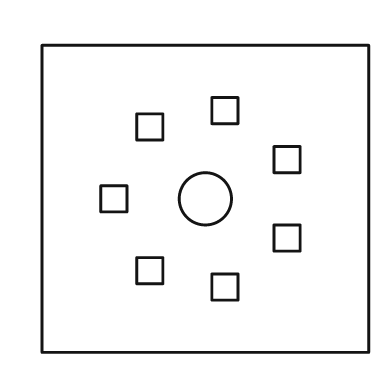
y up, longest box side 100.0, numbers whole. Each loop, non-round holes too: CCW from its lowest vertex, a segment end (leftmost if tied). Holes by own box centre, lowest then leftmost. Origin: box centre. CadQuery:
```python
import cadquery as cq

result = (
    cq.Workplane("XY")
    .moveTo(-50.0, -47.0)
    .lineTo(50.0, -47.0)
    .lineTo(50.0, 47.0)
    .lineTo(-50.0, 47.0)
    .close()
    .moveTo(2.0, -31.0)
    .lineTo(10.0, -31.0)
    .lineTo(10.0, -23.0)
    .lineTo(2.0, -23.0)
    .close()
    .moveTo(-21.0, -26.0)
    .lineTo(-13.0, -26.0)
    .lineTo(-13.0, -18.0)
    .lineTo(-21.0, -18.0)
    .close()
    .moveTo(21.0, -16.0)
    .lineTo(29.0, -16.0)
    .lineTo(29.0, -8.0)
    .lineTo(21.0, -8.0)
    .close()
    .moveTo(-32.0, -4.0)
    .lineTo(-24.0, -4.0)
    .lineTo(-24.0, 4.0)
    .lineTo(-32.0, 4.0)
    .close()
    .moveTo(0.0, 0.0)
    .circle(8.0)
    .moveTo(21.0, 8.0)
    .lineTo(29.0, 8.0)
    .lineTo(29.0, 16.0)
    .lineTo(21.0, 16.0)
    .close()
    .moveTo(-21.0, 18.0)
    .lineTo(-13.0, 18.0)
    .lineTo(-13.0, 26.0)
    .lineTo(-21.0, 26.0)
    .close()
    .moveTo(2.0, 23.0)
    .lineTo(10.0, 23.0)
    .lineTo(10.0, 31.0)
    .lineTo(2.0, 31.0)
    .close()
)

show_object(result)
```